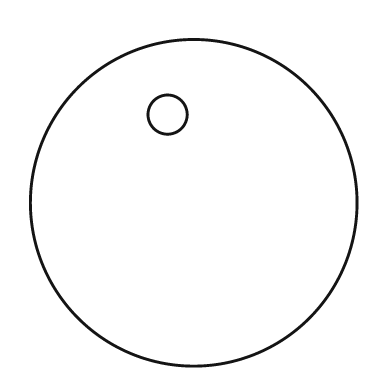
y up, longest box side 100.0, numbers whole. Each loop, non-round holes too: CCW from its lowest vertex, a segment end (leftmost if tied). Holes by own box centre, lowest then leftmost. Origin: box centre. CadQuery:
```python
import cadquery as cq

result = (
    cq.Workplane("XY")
    .moveTo(0.0, 0.0)
    .circle(50.0)
    .moveTo(-8.0, 27.0)
    .circle(6.0)
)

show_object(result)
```